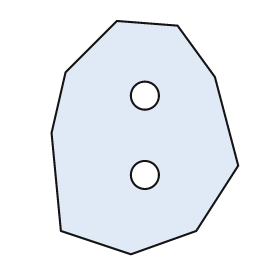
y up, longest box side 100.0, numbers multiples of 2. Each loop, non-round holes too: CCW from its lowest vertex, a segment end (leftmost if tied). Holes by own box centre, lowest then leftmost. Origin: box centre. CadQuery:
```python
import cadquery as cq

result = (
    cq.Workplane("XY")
    .moveTo(-6.0, -50.0)
    .lineTo(22.0, -40.0)
    .lineTo(40.0, -12.0)
    .lineTo(30.0, 26.0)
    .lineTo(14.0, 48.0)
    .lineTo(-12.0, 50.0)
    .lineTo(-34.0, 28.0)
    .lineTo(-40.0, 2.0)
    .lineTo(-36.0, -40.0)
    .close()
    .moveTo(0.0, -16.0)
    .circle(6.0)
    .moveTo(0.0, 18.0)
    .circle(6.0)
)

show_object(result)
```